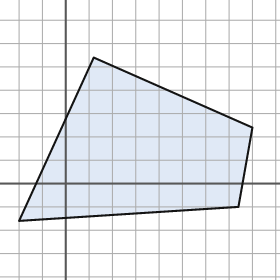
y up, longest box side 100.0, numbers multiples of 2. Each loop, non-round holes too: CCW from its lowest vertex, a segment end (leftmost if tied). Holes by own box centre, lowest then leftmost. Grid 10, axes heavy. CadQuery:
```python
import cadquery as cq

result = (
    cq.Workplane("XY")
    .moveTo(-20.0, -16.0)
    .lineTo(74.0, -10.0)
    .lineTo(80.0, 24.0)
    .lineTo(12.0, 54.0)
    .close()
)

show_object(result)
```